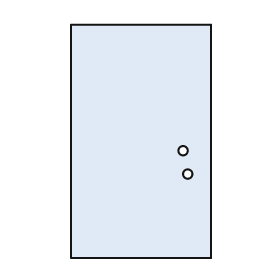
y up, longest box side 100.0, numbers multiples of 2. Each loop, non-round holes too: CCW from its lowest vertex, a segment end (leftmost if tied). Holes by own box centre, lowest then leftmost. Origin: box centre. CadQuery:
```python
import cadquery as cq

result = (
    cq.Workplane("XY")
    .moveTo(-30.0, -50.0)
    .lineTo(30.0, -50.0)
    .lineTo(30.0, 50.0)
    .lineTo(-30.0, 50.0)
    .close()
    .moveTo(20.0, -14.0)
    .circle(2.0)
    .moveTo(18.0, -4.0)
    .circle(2.0)
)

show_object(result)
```